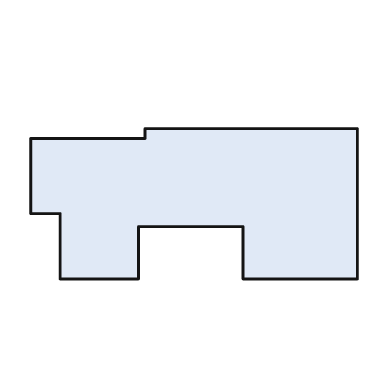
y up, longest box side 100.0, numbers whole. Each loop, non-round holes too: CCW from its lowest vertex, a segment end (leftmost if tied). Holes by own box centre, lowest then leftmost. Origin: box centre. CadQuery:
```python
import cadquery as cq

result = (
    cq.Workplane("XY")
    .moveTo(-41.0, -23.0)
    .lineTo(-17.0, -23.0)
    .lineTo(-17.0, -7.0)
    .lineTo(15.0, -7.0)
    .lineTo(15.0, -23.0)
    .lineTo(50.0, -23.0)
    .lineTo(50.0, 23.0)
    .lineTo(-15.0, 23.0)
    .lineTo(-15.0, 20.0)
    .lineTo(-50.0, 20.0)
    .lineTo(-50.0, -3.0)
    .lineTo(-41.0, -3.0)
    .close()
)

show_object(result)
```